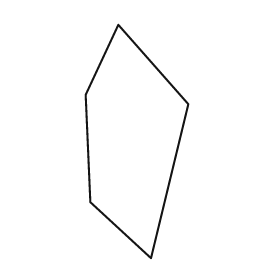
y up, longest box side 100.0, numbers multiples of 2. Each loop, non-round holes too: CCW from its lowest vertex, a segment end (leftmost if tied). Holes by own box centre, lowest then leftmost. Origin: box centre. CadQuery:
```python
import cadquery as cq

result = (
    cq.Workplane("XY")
    .moveTo(6.0, -50.0)
    .lineTo(22.0, 16.0)
    .lineTo(-8.0, 50.0)
    .lineTo(-22.0, 20.0)
    .lineTo(-20.0, -26.0)
    .close()
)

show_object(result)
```